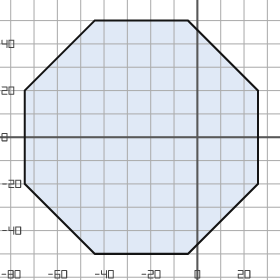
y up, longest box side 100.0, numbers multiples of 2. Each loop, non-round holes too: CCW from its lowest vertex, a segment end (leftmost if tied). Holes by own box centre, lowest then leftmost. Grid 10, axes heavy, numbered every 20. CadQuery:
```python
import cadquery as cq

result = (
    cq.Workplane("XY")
    .moveTo(-44.0, -50.0)
    .lineTo(-4.0, -50.0)
    .lineTo(26.0, -20.0)
    .lineTo(26.0, 20.0)
    .lineTo(-4.0, 50.0)
    .lineTo(-44.0, 50.0)
    .lineTo(-74.0, 20.0)
    .lineTo(-74.0, -20.0)
    .close()
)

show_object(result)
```